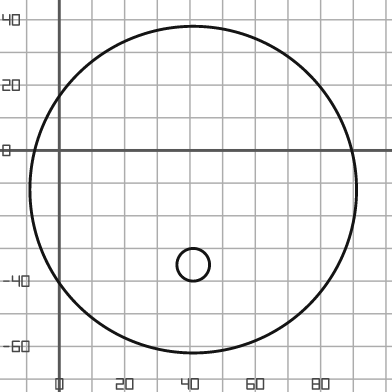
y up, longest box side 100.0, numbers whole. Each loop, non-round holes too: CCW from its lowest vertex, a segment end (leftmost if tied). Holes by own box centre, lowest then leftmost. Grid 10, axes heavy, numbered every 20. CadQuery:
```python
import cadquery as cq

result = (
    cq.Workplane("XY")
    .moveTo(41.0, -12.0)
    .circle(50.0)
    .moveTo(41.0, -35.0)
    .circle(5.0)
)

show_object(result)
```